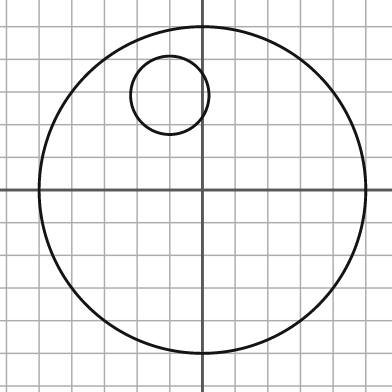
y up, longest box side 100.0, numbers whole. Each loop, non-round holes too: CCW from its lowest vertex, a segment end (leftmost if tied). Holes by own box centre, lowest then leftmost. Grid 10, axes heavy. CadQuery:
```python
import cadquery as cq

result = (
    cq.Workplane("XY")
    .moveTo(0.0, 0.0)
    .circle(50.0)
    .moveTo(-10.0, 29.0)
    .circle(12.0)
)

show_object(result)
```